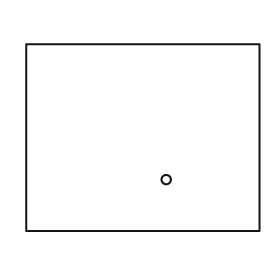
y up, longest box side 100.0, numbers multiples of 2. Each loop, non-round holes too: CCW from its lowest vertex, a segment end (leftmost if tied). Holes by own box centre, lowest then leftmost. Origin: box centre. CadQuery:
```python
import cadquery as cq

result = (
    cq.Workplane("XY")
    .moveTo(-50.0, -40.0)
    .lineTo(50.0, -40.0)
    .lineTo(50.0, 40.0)
    .lineTo(-50.0, 40.0)
    .close()
    .moveTo(10.0, -18.0)
    .circle(2.0)
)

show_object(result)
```